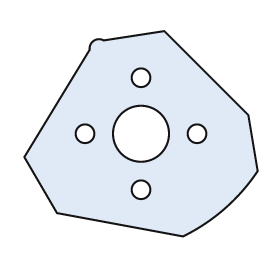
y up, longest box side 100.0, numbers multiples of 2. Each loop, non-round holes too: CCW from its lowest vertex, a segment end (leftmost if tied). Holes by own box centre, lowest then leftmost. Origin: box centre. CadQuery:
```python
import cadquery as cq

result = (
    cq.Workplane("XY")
    .moveTo(18.0, -44.0)
    .threePointArc((36.0, -32.0), (50.0, -16.0))
    .lineTo(46.0, 8.0)
    .lineTo(10.0, 44.0)
    .lineTo(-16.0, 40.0)
    .threePointArc((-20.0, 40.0), (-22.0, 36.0))
    .lineTo(-50.0, -10.0)
    .lineTo(-36.0, -34.0)
    .close()
    .moveTo(0.0, -24.0)
    .circle(4.0)
    .moveTo(-24.0, 0.0)
    .circle(4.0)
    .moveTo(0.0, 0.0)
    .circle(12.0)
    .moveTo(24.0, 0.0)
    .circle(4.0)
    .moveTo(0.0, 24.0)
    .circle(4.0)
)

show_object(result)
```